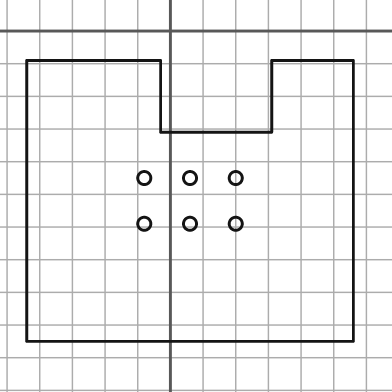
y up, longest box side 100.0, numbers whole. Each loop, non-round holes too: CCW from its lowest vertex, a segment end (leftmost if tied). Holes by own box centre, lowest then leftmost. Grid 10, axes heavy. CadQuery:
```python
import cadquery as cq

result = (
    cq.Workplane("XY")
    .moveTo(-44.0, -95.0)
    .lineTo(56.0, -95.0)
    .lineTo(56.0, -9.0)
    .lineTo(31.0, -9.0)
    .lineTo(31.0, -31.0)
    .lineTo(-3.0, -31.0)
    .lineTo(-3.0, -9.0)
    .lineTo(-44.0, -9.0)
    .close()
    .moveTo(-8.0, -59.0)
    .circle(2.0)
    .moveTo(6.0, -59.0)
    .circle(2.0)
    .moveTo(20.0, -59.0)
    .circle(2.0)
    .moveTo(-8.0, -45.0)
    .circle(2.0)
    .moveTo(6.0, -45.0)
    .circle(2.0)
    .moveTo(20.0, -45.0)
    .circle(2.0)
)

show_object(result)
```